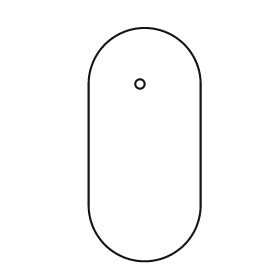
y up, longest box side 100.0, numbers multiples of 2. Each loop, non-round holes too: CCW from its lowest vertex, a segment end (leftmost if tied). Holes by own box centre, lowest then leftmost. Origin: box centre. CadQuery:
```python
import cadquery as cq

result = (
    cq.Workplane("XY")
    .moveTo(-24.0, -26.0)
    .threePointArc((0.0, -50.0), (24.0, -26.0))
    .lineTo(24.0, 26.0)
    .threePointArc((0.0, 50.0), (-24.0, 26.0))
    .close()
    .moveTo(-2.0, 26.0)
    .circle(2.0)
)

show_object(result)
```